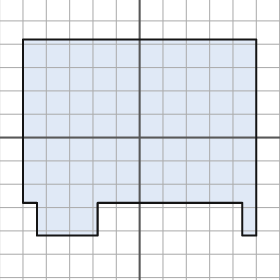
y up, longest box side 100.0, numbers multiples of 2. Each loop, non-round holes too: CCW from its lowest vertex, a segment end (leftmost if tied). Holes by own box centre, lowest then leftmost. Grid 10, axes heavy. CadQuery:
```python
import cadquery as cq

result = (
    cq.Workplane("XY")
    .moveTo(-44.0, -42.0)
    .lineTo(-18.0, -42.0)
    .lineTo(-18.0, -28.0)
    .lineTo(44.0, -28.0)
    .lineTo(44.0, -42.0)
    .lineTo(50.0, -42.0)
    .lineTo(50.0, 42.0)
    .lineTo(-50.0, 42.0)
    .lineTo(-50.0, -28.0)
    .lineTo(-44.0, -28.0)
    .close()
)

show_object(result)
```